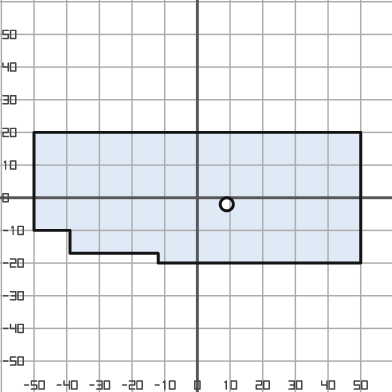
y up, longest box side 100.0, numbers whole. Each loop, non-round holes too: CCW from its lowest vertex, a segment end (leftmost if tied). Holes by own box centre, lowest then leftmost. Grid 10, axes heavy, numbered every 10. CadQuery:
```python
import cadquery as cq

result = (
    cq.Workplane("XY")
    .moveTo(-12.0, -20.0)
    .lineTo(50.0, -20.0)
    .lineTo(50.0, 20.0)
    .lineTo(-50.0, 20.0)
    .lineTo(-50.0, -10.0)
    .lineTo(-39.0, -10.0)
    .lineTo(-39.0, -17.0)
    .lineTo(-12.0, -17.0)
    .close()
    .moveTo(9.0, -2.0)
    .circle(2.0)
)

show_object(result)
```